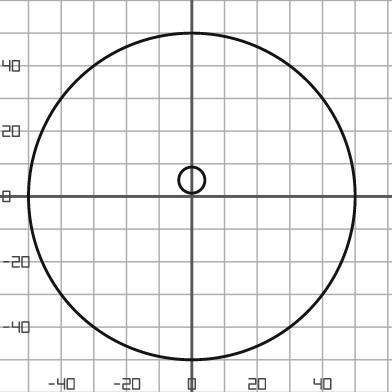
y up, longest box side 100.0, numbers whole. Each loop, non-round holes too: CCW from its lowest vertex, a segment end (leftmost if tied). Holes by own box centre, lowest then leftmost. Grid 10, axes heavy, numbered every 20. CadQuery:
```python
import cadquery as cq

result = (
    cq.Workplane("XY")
    .moveTo(0.0, 0.0)
    .circle(50.0)
    .moveTo(0.0, 5.0)
    .circle(4.0)
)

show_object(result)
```